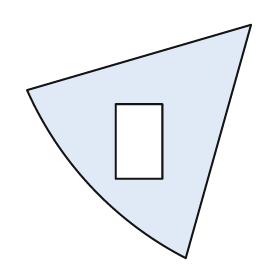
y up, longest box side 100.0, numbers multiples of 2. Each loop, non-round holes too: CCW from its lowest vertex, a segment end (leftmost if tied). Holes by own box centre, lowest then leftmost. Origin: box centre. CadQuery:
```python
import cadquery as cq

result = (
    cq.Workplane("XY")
    .moveTo(20.0, -50.0)
    .lineTo(48.0, 50.0)
    .lineTo(-48.0, 22.0)
    .threePointArc((-20.0, -20.0), (20.0, -50.0))
    .close()
    .moveTo(-10.0, -16.0)
    .lineTo(10.0, -16.0)
    .lineTo(10.0, 16.0)
    .lineTo(-10.0, 16.0)
    .close()
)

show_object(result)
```